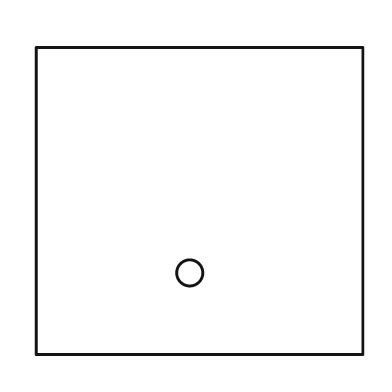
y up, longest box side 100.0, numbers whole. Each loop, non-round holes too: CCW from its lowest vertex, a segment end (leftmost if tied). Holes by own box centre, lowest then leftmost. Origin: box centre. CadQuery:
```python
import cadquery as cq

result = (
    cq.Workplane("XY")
    .moveTo(-50.0, -47.0)
    .lineTo(50.0, -47.0)
    .lineTo(50.0, 47.0)
    .lineTo(-50.0, 47.0)
    .close()
    .moveTo(-3.0, -22.0)
    .circle(4.0)
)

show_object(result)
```